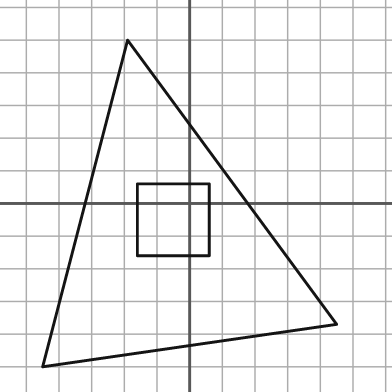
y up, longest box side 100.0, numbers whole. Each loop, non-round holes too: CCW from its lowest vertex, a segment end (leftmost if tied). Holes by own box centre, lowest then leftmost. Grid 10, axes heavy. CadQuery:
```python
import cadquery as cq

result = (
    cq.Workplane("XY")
    .moveTo(-45.0, -50.0)
    .lineTo(45.0, -37.0)
    .lineTo(-19.0, 50.0)
    .close()
    .moveTo(-16.0, -16.0)
    .lineTo(6.0, -16.0)
    .lineTo(6.0, 6.0)
    .lineTo(-16.0, 6.0)
    .close()
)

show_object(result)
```